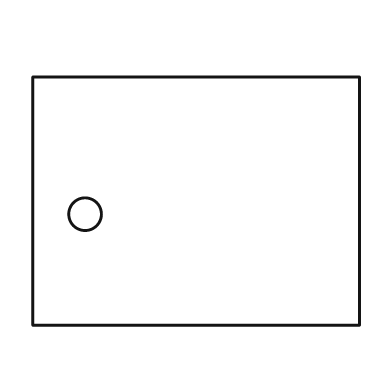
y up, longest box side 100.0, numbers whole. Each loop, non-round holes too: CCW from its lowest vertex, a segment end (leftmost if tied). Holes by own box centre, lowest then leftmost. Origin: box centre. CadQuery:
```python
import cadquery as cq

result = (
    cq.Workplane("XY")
    .moveTo(-50.0, -38.0)
    .lineTo(50.0, -38.0)
    .lineTo(50.0, 38.0)
    .lineTo(-50.0, 38.0)
    .close()
    .moveTo(-34.0, -4.0)
    .circle(5.0)
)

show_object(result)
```